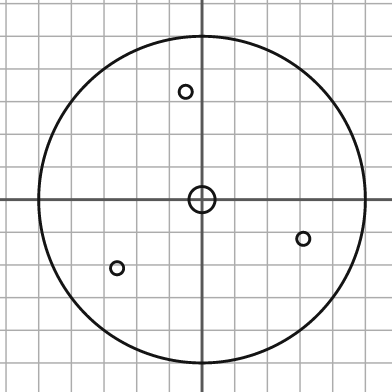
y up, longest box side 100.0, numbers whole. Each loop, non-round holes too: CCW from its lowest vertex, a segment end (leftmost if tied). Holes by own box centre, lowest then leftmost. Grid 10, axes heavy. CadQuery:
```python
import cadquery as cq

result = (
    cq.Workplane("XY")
    .moveTo(0.0, 0.0)
    .circle(50.0)
    .moveTo(-26.0, -21.0)
    .circle(2.0)
    .moveTo(31.0, -12.0)
    .circle(2.0)
    .moveTo(0.0, 0.0)
    .circle(4.0)
    .moveTo(-5.0, 33.0)
    .circle(2.0)
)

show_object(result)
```